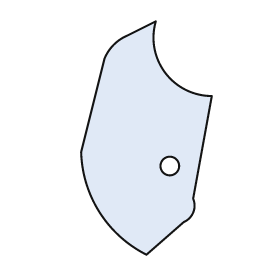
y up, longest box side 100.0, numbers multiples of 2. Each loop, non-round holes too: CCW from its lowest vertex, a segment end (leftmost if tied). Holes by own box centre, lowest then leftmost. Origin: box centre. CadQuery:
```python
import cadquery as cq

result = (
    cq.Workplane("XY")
    .moveTo(0.0, -50.0)
    .lineTo(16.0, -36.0)
    .threePointArc((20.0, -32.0), (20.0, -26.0))
    .lineTo(28.0, 18.0)
    .threePointArc((8.0, 28.0), (4.0, 50.0))
    .lineTo(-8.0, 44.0)
    .threePointArc((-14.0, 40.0), (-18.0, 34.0))
    .lineTo(-28.0, -6.0)
    .threePointArc((-20.0, -32.0), (0.0, -50.0))
    .close()
    .moveTo(10.0, -12.0)
    .circle(4.0)
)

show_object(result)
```